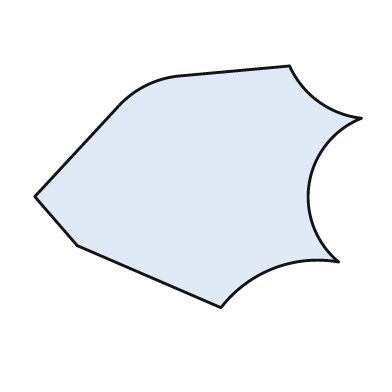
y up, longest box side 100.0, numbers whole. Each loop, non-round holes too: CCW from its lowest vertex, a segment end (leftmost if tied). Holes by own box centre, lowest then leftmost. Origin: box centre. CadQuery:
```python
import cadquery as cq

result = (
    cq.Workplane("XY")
    .moveTo(7.0, -37.0)
    .threePointArc((23.0, -25.0), (43.0, -23.0))
    .threePointArc((34.0, 1.0), (50.0, 21.0))
    .threePointArc((37.0, 26.0), (28.0, 37.0))
    .lineTo(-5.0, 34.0)
    .threePointArc((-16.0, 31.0), (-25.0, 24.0))
    .lineTo(-50.0, -3.0)
    .lineTo(-37.0, -18.0)
    .close()
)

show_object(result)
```